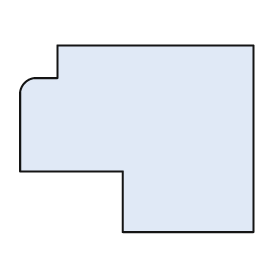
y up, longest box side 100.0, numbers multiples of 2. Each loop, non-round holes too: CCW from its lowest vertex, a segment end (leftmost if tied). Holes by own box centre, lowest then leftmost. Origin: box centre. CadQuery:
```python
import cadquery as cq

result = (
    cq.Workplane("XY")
    .moveTo(-6.0, -40.0)
    .lineTo(50.0, -40.0)
    .lineTo(50.0, 40.0)
    .lineTo(-34.0, 40.0)
    .lineTo(-34.0, 26.0)
    .lineTo(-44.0, 26.0)
    .threePointArc((-48.0, 24.0), (-50.0, 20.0))
    .lineTo(-50.0, -14.0)
    .lineTo(-6.0, -14.0)
    .close()
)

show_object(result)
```